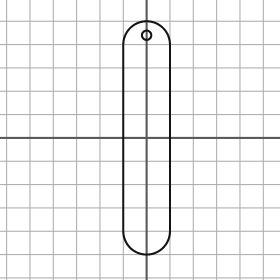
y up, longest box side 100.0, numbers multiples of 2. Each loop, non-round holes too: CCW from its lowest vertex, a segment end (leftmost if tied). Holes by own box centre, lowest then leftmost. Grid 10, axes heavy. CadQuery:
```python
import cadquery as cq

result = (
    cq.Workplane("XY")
    .moveTo(-10.0, -40.0)
    .threePointArc((0.0, -50.0), (10.0, -40.0))
    .lineTo(10.0, 40.0)
    .threePointArc((0.0, 50.0), (-10.0, 40.0))
    .close()
    .moveTo(0.0, 44.0)
    .circle(2.0)
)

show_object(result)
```